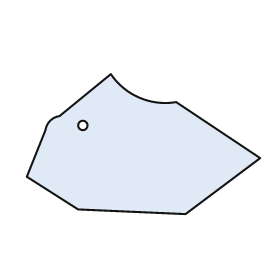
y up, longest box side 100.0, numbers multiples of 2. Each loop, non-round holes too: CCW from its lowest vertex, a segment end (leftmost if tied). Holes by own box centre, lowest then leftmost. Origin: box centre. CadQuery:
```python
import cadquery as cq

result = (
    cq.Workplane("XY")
    .moveTo(18.0, -30.0)
    .lineTo(50.0, -6.0)
    .lineTo(14.0, 18.0)
    .threePointArc((-2.0, 20.0), (-14.0, 30.0))
    .lineTo(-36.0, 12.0)
    .threePointArc((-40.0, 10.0), (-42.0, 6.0))
    .lineTo(-50.0, -14.0)
    .lineTo(-28.0, -28.0)
    .close()
    .moveTo(-26.0, 8.0)
    .circle(2.0)
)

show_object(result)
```